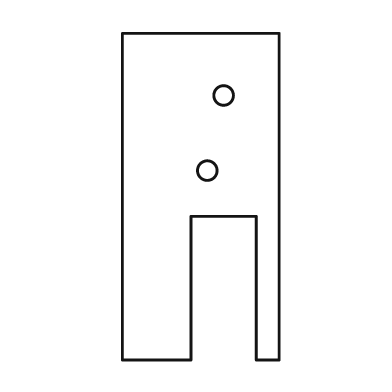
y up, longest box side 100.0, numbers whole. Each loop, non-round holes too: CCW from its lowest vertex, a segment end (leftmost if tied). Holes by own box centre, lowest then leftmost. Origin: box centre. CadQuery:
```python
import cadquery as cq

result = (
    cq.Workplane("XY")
    .moveTo(-24.0, -50.0)
    .lineTo(-3.0, -50.0)
    .lineTo(-3.0, -6.0)
    .lineTo(17.0, -6.0)
    .lineTo(17.0, -50.0)
    .lineTo(24.0, -50.0)
    .lineTo(24.0, 50.0)
    .lineTo(-24.0, 50.0)
    .close()
    .moveTo(2.0, 8.0)
    .circle(3.0)
    .moveTo(7.0, 31.0)
    .circle(3.0)
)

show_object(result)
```